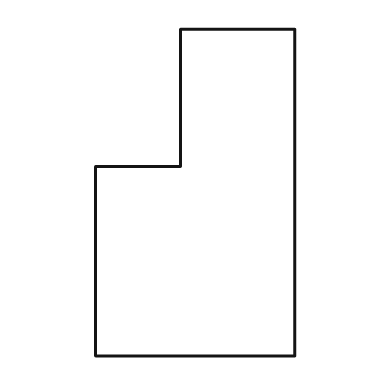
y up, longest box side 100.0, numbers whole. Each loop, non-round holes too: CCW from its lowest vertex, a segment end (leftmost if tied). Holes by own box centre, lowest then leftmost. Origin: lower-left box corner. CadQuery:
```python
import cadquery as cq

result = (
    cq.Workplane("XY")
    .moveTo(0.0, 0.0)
    .lineTo(61.0, 0.0)
    .lineTo(61.0, 100.0)
    .lineTo(26.0, 100.0)
    .lineTo(26.0, 58.0)
    .lineTo(0.0, 58.0)
    .close()
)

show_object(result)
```